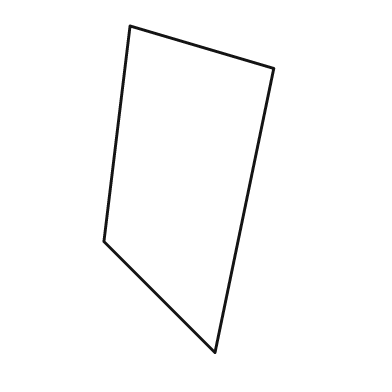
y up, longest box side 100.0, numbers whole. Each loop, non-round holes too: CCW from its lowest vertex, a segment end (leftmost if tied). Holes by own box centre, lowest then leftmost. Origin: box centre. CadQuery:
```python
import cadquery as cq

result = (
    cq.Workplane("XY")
    .moveTo(8.0, -50.0)
    .lineTo(26.0, 37.0)
    .lineTo(-18.0, 50.0)
    .lineTo(-26.0, -16.0)
    .close()
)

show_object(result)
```